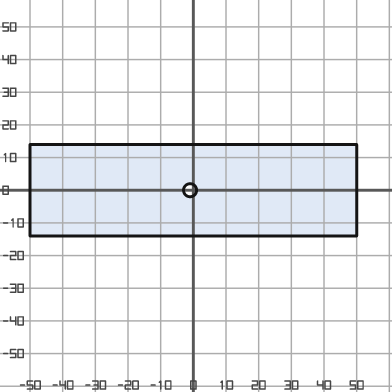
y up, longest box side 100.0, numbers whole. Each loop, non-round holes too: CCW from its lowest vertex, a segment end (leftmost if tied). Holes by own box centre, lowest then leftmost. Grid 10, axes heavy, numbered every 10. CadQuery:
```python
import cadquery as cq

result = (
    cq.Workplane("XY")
    .moveTo(-50.0, -14.0)
    .lineTo(50.0, -14.0)
    .lineTo(50.0, 14.0)
    .lineTo(-50.0, 14.0)
    .close()
    .moveTo(-1.0, 0.0)
    .circle(2.0)
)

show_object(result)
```